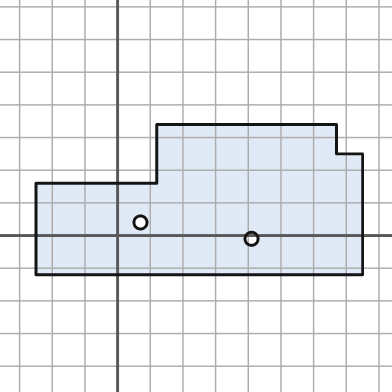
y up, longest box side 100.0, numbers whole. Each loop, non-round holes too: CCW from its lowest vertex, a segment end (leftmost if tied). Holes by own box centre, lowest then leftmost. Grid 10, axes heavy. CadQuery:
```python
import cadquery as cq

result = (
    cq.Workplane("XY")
    .moveTo(-25.0, -12.0)
    .lineTo(75.0, -12.0)
    .lineTo(75.0, 25.0)
    .lineTo(67.0, 25.0)
    .lineTo(67.0, 34.0)
    .lineTo(12.0, 34.0)
    .lineTo(12.0, 16.0)
    .lineTo(-25.0, 16.0)
    .close()
    .moveTo(41.0, -1.0)
    .circle(2.0)
    .moveTo(7.0, 4.0)
    .circle(2.0)
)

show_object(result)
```